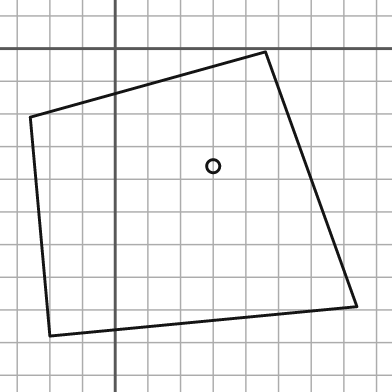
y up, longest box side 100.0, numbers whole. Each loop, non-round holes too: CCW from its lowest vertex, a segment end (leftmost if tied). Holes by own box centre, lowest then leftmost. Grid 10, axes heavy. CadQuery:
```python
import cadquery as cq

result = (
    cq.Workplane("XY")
    .moveTo(-20.0, -88.0)
    .lineTo(74.0, -79.0)
    .lineTo(46.0, -1.0)
    .lineTo(-26.0, -21.0)
    .close()
    .moveTo(30.0, -36.0)
    .circle(2.0)
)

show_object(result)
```